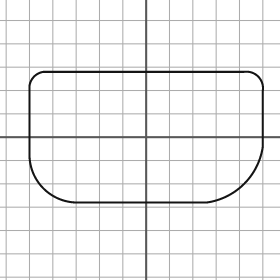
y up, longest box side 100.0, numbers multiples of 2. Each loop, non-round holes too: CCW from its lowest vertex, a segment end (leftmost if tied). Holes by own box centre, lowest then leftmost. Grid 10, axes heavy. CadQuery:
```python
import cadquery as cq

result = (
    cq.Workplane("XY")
    .moveTo(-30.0, -28.0)
    .lineTo(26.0, -28.0)
    .threePointArc((42.0, -20.0), (50.0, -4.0))
    .lineTo(50.0, 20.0)
    .threePointArc((48.0, 26.0), (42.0, 28.0))
    .lineTo(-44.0, 28.0)
    .threePointArc((-48.0, 26.0), (-50.0, 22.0))
    .lineTo(-50.0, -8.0)
    .threePointArc((-44.0, -22.0), (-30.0, -28.0))
    .close()
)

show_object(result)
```